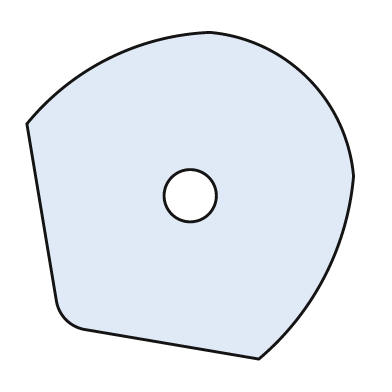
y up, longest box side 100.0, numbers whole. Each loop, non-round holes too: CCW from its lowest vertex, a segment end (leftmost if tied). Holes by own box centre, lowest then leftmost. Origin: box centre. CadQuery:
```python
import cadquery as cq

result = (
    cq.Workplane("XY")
    .moveTo(21.0, -50.0)
    .threePointArc((41.0, -25.0), (50.0, 6.0))
    .threePointArc((36.0, 36.0), (6.0, 50.0))
    .threePointArc((-25.0, 42.0), (-50.0, 22.0))
    .lineTo(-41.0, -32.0)
    .threePointArc((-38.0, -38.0), (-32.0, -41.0))
    .close()
    .moveTo(0.0, 0.0)
    .circle(8.0)
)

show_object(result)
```